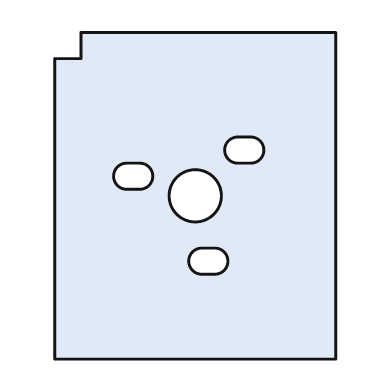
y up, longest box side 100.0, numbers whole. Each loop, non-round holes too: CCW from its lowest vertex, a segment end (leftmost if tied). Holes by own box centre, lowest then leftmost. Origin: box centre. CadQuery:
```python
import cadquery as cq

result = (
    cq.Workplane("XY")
    .moveTo(-43.0, -50.0)
    .lineTo(43.0, -50.0)
    .lineTo(43.0, 50.0)
    .lineTo(-35.0, 50.0)
    .lineTo(-35.0, 42.0)
    .lineTo(-43.0, 42.0)
    .close()
    .moveTo(2.0, -24.0)
    .lineTo(6.0, -24.0)
    .threePointArc((10.0, -20.0), (6.0, -16.0))
    .lineTo(2.0, -16.0)
    .threePointArc((-2.0, -20.0), (2.0, -24.0))
    .close()
    .moveTo(0.0, 0.0)
    .circle(8.0)
    .moveTo(-21.0, 2.0)
    .lineTo(-17.0, 2.0)
    .threePointArc((-13.0, 6.0), (-17.0, 10.0))
    .lineTo(-21.0, 10.0)
    .threePointArc((-25.0, 6.0), (-21.0, 2.0))
    .close()
    .moveTo(13.0, 10.0)
    .lineTo(17.0, 10.0)
    .threePointArc((21.0, 14.0), (17.0, 18.0))
    .lineTo(13.0, 18.0)
    .threePointArc((9.0, 14.0), (13.0, 10.0))
    .close()
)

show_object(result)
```